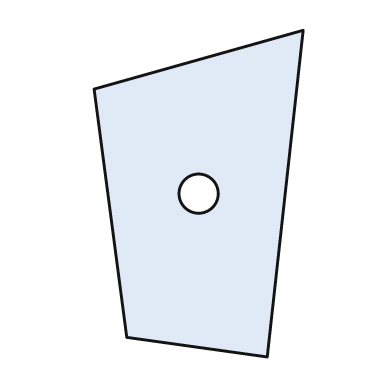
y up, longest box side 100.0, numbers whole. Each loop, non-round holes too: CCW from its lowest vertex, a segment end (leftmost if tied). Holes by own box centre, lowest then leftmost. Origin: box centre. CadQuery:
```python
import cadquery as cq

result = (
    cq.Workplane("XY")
    .moveTo(21.0, -50.0)
    .lineTo(32.0, 50.0)
    .lineTo(-32.0, 32.0)
    .lineTo(-22.0, -44.0)
    .close()
    .moveTo(0.0, 0.0)
    .circle(6.0)
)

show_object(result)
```